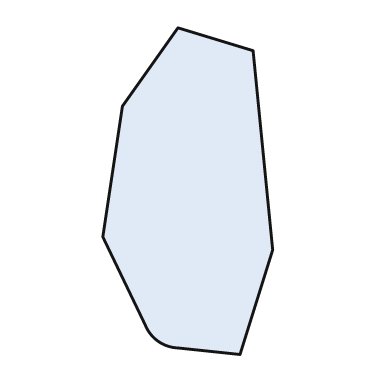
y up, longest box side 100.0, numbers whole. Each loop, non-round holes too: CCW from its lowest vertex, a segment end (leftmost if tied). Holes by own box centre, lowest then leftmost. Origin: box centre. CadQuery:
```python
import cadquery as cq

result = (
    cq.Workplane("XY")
    .moveTo(16.0, -50.0)
    .lineTo(26.0, -18.0)
    .lineTo(20.0, 43.0)
    .lineTo(-3.0, 50.0)
    .lineTo(-20.0, 26.0)
    .lineTo(-26.0, -14.0)
    .lineTo(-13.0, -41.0)
    .threePointArc((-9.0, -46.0), (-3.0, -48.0))
    .close()
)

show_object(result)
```